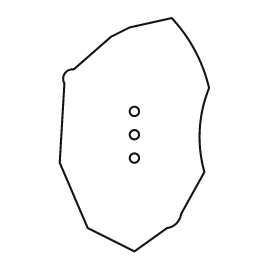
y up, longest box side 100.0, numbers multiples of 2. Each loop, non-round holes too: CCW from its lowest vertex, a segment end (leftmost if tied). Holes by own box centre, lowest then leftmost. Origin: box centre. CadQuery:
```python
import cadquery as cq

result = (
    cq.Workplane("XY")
    .moveTo(0.0, -50.0)
    .lineTo(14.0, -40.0)
    .threePointArc((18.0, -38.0), (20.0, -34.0))
    .lineTo(30.0, -16.0)
    .threePointArc((28.0, 2.0), (32.0, 20.0))
    .threePointArc((26.0, 36.0), (16.0, 50.0))
    .lineTo(-2.0, 46.0)
    .lineTo(-10.0, 42.0)
    .lineTo(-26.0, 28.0)
    .threePointArc((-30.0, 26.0), (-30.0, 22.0))
    .lineTo(-32.0, -12.0)
    .lineTo(-20.0, -40.0)
    .close()
    .moveTo(0.0, -10.0)
    .circle(2.0)
    .moveTo(0.0, 0.0)
    .circle(2.0)
    .moveTo(0.0, 10.0)
    .circle(2.0)
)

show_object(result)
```